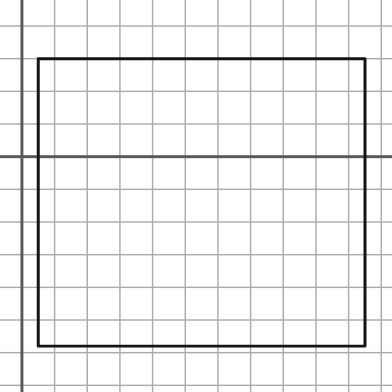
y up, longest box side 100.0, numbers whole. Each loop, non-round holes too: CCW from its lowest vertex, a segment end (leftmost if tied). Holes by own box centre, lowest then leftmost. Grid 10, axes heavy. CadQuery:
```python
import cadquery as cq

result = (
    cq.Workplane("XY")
    .moveTo(5.0, -58.0)
    .lineTo(105.0, -58.0)
    .lineTo(105.0, 30.0)
    .lineTo(5.0, 30.0)
    .close()
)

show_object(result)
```